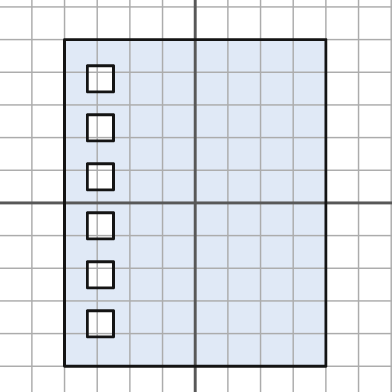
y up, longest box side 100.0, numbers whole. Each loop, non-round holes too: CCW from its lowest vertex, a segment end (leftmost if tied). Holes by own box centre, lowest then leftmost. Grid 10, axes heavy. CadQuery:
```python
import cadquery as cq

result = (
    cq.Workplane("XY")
    .moveTo(-40.0, -50.0)
    .lineTo(40.0, -50.0)
    .lineTo(40.0, 50.0)
    .lineTo(-40.0, 50.0)
    .close()
    .moveTo(-33.0, -41.0)
    .lineTo(-25.0, -41.0)
    .lineTo(-25.0, -33.0)
    .lineTo(-33.0, -33.0)
    .close()
    .moveTo(-33.0, -26.0)
    .lineTo(-25.0, -26.0)
    .lineTo(-25.0, -18.0)
    .lineTo(-33.0, -18.0)
    .close()
    .moveTo(-33.0, -11.0)
    .lineTo(-25.0, -11.0)
    .lineTo(-25.0, -3.0)
    .lineTo(-33.0, -3.0)
    .close()
    .moveTo(-33.0, 4.0)
    .lineTo(-25.0, 4.0)
    .lineTo(-25.0, 12.0)
    .lineTo(-33.0, 12.0)
    .close()
    .moveTo(-33.0, 19.0)
    .lineTo(-25.0, 19.0)
    .lineTo(-25.0, 27.0)
    .lineTo(-33.0, 27.0)
    .close()
    .moveTo(-33.0, 34.0)
    .lineTo(-25.0, 34.0)
    .lineTo(-25.0, 42.0)
    .lineTo(-33.0, 42.0)
    .close()
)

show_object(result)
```